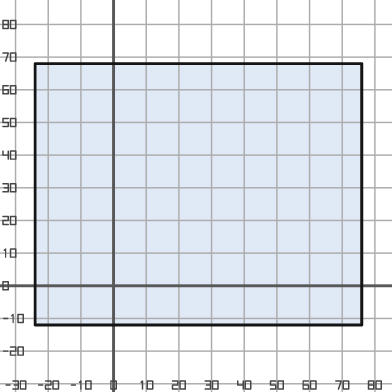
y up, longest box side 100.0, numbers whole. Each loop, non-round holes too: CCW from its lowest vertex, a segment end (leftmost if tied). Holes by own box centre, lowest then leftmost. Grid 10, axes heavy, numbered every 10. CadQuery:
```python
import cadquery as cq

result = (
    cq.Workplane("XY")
    .moveTo(-24.0, -12.0)
    .lineTo(76.0, -12.0)
    .lineTo(76.0, 68.0)
    .lineTo(-24.0, 68.0)
    .close()
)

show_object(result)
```